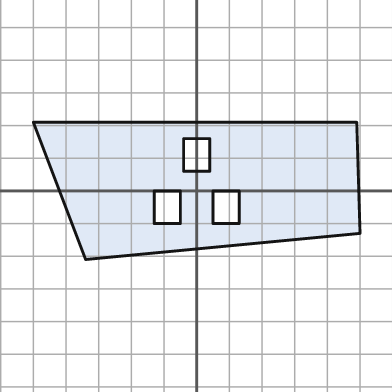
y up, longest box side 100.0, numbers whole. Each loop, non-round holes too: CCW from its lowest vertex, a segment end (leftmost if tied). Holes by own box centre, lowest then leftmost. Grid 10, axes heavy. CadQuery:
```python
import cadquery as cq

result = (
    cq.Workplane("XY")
    .moveTo(-34.0, -21.0)
    .lineTo(50.0, -13.0)
    .lineTo(49.0, 21.0)
    .lineTo(-50.0, 21.0)
    .close()
    .moveTo(-13.0, -10.0)
    .lineTo(-5.0, -10.0)
    .lineTo(-5.0, 0.0)
    .lineTo(-13.0, 0.0)
    .close()
    .moveTo(5.0, -10.0)
    .lineTo(13.0, -10.0)
    .lineTo(13.0, 0.0)
    .lineTo(5.0, 0.0)
    .close()
    .moveTo(-4.0, 6.0)
    .lineTo(4.0, 6.0)
    .lineTo(4.0, 16.0)
    .lineTo(-4.0, 16.0)
    .close()
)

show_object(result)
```